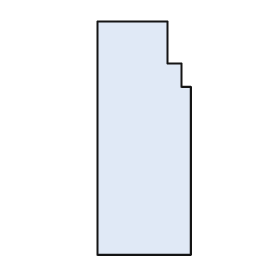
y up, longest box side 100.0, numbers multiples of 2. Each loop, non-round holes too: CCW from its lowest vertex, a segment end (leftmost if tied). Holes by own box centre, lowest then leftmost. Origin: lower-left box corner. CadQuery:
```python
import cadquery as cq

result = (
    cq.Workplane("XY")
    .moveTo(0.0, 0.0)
    .lineTo(40.0, 0.0)
    .lineTo(40.0, 72.0)
    .lineTo(36.0, 72.0)
    .lineTo(36.0, 82.0)
    .lineTo(30.0, 82.0)
    .lineTo(30.0, 100.0)
    .lineTo(0.0, 100.0)
    .close()
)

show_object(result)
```